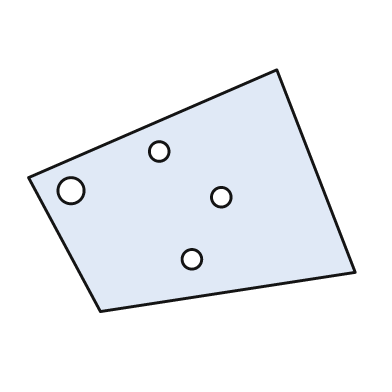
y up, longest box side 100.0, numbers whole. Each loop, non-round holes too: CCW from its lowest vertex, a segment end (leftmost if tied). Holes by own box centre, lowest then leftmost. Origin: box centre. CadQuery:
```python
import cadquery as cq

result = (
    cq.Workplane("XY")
    .moveTo(-28.0, -37.0)
    .lineTo(50.0, -25.0)
    .lineTo(26.0, 37.0)
    .lineTo(-50.0, 4.0)
    .close()
    .moveTo(0.0, -21.0)
    .circle(3.0)
    .moveTo(9.0, -2.0)
    .circle(3.0)
    .moveTo(-37.0, 0.0)
    .circle(4.0)
    .moveTo(-10.0, 12.0)
    .circle(3.0)
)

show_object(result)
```